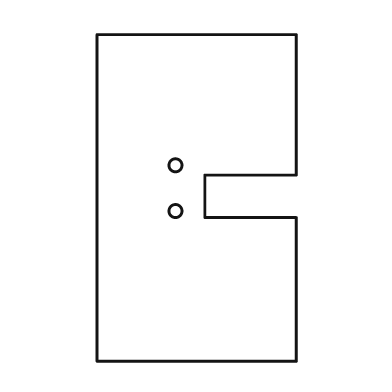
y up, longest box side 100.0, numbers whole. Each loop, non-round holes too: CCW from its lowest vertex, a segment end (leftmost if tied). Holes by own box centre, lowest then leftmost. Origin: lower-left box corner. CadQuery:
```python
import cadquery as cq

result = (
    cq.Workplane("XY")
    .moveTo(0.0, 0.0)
    .lineTo(61.0, 0.0)
    .lineTo(61.0, 44.0)
    .lineTo(33.0, 44.0)
    .lineTo(33.0, 57.0)
    .lineTo(61.0, 57.0)
    .lineTo(61.0, 100.0)
    .lineTo(0.0, 100.0)
    .close()
    .moveTo(24.0, 46.0)
    .circle(2.0)
    .moveTo(24.0, 60.0)
    .circle(2.0)
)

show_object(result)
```